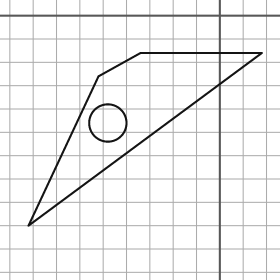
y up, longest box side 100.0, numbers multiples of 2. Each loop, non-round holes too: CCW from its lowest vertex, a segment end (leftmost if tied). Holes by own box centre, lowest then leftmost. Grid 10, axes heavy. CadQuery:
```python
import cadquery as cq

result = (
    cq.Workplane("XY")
    .moveTo(-82.0, -90.0)
    .lineTo(18.0, -16.0)
    .lineTo(-34.0, -16.0)
    .lineTo(-52.0, -26.0)
    .close()
    .moveTo(-48.0, -46.0)
    .circle(8.0)
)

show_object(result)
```